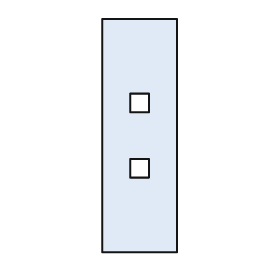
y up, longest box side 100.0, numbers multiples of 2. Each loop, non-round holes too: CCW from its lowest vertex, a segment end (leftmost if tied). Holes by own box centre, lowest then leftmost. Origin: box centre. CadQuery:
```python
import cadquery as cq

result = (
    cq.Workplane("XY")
    .moveTo(-16.0, -50.0)
    .lineTo(16.0, -50.0)
    .lineTo(16.0, 50.0)
    .lineTo(-16.0, 50.0)
    .close()
    .moveTo(-4.0, -18.0)
    .lineTo(4.0, -18.0)
    .lineTo(4.0, -10.0)
    .lineTo(-4.0, -10.0)
    .close()
    .moveTo(-4.0, 10.0)
    .lineTo(4.0, 10.0)
    .lineTo(4.0, 18.0)
    .lineTo(-4.0, 18.0)
    .close()
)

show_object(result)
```